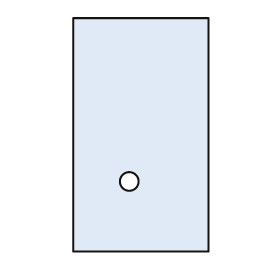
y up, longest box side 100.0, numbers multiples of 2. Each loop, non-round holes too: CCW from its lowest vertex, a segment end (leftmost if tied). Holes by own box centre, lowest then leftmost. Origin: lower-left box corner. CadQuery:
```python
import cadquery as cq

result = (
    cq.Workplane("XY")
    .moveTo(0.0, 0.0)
    .lineTo(58.0, 0.0)
    .lineTo(58.0, 100.0)
    .lineTo(0.0, 100.0)
    .close()
    .moveTo(24.0, 30.0)
    .circle(4.0)
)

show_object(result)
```